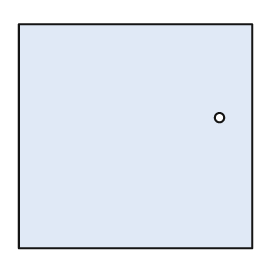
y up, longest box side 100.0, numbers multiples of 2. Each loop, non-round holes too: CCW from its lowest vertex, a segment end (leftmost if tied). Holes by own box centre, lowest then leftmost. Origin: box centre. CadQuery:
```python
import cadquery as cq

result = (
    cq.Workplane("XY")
    .moveTo(-50.0, -48.0)
    .lineTo(50.0, -48.0)
    .lineTo(50.0, 48.0)
    .lineTo(-50.0, 48.0)
    .close()
    .moveTo(36.0, 8.0)
    .circle(2.0)
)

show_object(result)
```